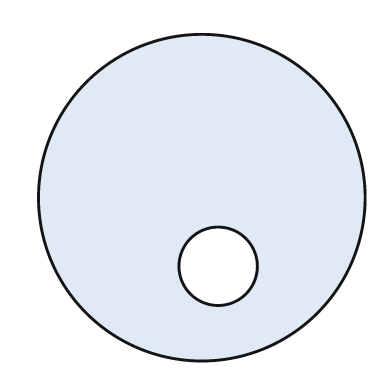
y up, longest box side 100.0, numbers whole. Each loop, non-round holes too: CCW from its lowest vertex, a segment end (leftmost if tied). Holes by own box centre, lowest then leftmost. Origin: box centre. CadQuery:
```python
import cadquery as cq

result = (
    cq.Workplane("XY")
    .moveTo(0.0, 0.0)
    .circle(50.0)
    .moveTo(5.0, -21.0)
    .circle(12.0)
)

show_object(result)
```